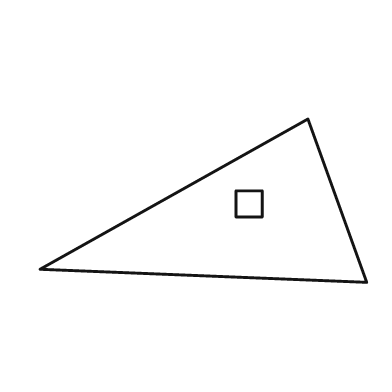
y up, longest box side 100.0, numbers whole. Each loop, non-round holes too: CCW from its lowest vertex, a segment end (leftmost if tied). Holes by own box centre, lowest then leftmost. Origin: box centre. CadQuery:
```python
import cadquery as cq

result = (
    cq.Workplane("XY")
    .moveTo(50.0, -25.0)
    .lineTo(32.0, 25.0)
    .lineTo(-50.0, -21.0)
    .close()
    .moveTo(10.0, -5.0)
    .lineTo(18.0, -5.0)
    .lineTo(18.0, 3.0)
    .lineTo(10.0, 3.0)
    .close()
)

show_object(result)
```